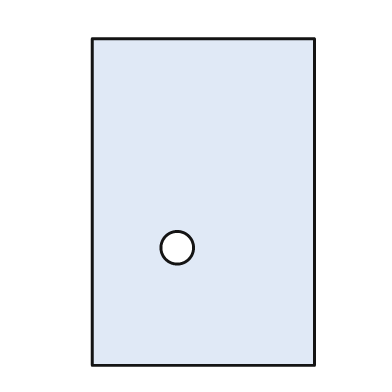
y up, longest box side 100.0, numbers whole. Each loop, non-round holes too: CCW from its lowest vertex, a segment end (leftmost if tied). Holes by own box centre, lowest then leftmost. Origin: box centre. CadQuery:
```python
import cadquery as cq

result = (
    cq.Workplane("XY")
    .moveTo(-34.0, -50.0)
    .lineTo(34.0, -50.0)
    .lineTo(34.0, 50.0)
    .lineTo(-34.0, 50.0)
    .close()
    .moveTo(-8.0, -14.0)
    .circle(5.0)
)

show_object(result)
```